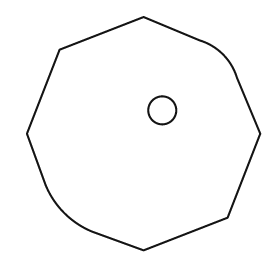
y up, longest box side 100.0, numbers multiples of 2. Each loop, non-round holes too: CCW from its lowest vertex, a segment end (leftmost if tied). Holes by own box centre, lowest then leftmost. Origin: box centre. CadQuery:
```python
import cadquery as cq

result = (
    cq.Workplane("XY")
    .moveTo(0.0, -50.0)
    .lineTo(36.0, -36.0)
    .lineTo(50.0, 0.0)
    .lineTo(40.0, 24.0)
    .threePointArc((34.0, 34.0), (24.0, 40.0))
    .lineTo(0.0, 50.0)
    .lineTo(-36.0, 36.0)
    .lineTo(-50.0, 0.0)
    .lineTo(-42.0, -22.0)
    .threePointArc((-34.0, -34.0), (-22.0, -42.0))
    .close()
    .moveTo(8.0, 10.0)
    .circle(6.0)
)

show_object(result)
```